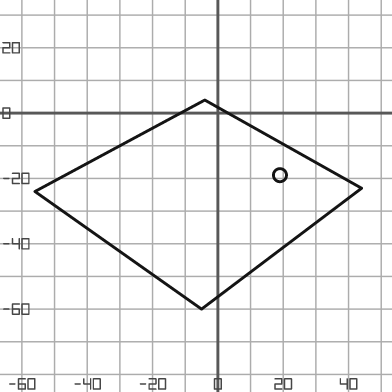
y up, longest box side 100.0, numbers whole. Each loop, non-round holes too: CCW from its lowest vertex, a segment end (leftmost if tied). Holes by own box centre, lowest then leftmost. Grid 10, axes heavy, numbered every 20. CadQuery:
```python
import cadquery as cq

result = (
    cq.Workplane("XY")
    .moveTo(-5.0, -60.0)
    .lineTo(44.0, -23.0)
    .lineTo(-4.0, 4.0)
    .lineTo(-56.0, -24.0)
    .close()
    .moveTo(19.0, -19.0)
    .circle(2.0)
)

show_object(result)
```